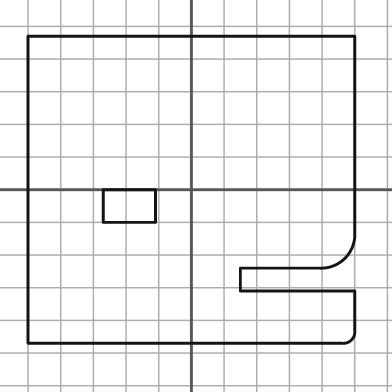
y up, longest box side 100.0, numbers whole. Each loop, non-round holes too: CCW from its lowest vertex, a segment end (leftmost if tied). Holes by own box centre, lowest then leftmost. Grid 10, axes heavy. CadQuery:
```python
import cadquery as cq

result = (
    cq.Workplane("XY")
    .moveTo(-50.0, -47.0)
    .lineTo(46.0, -47.0)
    .threePointArc((49.0, -46.0), (50.0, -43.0))
    .lineTo(50.0, -31.0)
    .lineTo(15.0, -31.0)
    .lineTo(15.0, -24.0)
    .lineTo(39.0, -24.0)
    .threePointArc((47.0, -21.0), (50.0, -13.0))
    .lineTo(50.0, 47.0)
    .lineTo(-50.0, 47.0)
    .close()
    .moveTo(-27.0, -10.0)
    .lineTo(-11.0, -10.0)
    .lineTo(-11.0, 0.0)
    .lineTo(-27.0, 0.0)
    .close()
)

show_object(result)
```